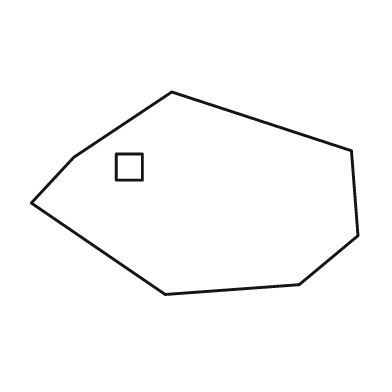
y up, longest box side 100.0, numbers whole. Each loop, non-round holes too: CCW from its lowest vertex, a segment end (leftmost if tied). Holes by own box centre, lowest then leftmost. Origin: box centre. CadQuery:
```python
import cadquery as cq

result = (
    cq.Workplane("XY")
    .moveTo(-9.0, -31.0)
    .lineTo(32.0, -28.0)
    .lineTo(50.0, -13.0)
    .lineTo(48.0, 13.0)
    .lineTo(-7.0, 31.0)
    .lineTo(-37.0, 11.0)
    .lineTo(-50.0, -3.0)
    .close()
    .moveTo(-24.0, 4.0)
    .lineTo(-16.0, 4.0)
    .lineTo(-16.0, 12.0)
    .lineTo(-24.0, 12.0)
    .close()
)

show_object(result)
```